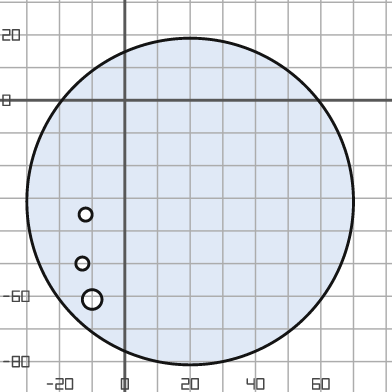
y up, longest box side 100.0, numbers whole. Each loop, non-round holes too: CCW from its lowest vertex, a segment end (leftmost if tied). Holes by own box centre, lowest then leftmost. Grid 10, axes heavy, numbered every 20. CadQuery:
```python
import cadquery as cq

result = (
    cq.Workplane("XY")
    .moveTo(20.0, -31.0)
    .circle(50.0)
    .moveTo(-10.0, -61.0)
    .circle(3.0)
    .moveTo(-13.0, -50.0)
    .circle(2.0)
    .moveTo(-12.0, -35.0)
    .circle(2.0)
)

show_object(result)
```